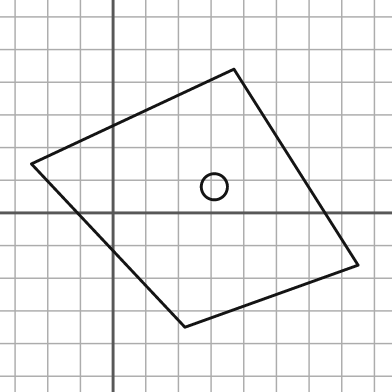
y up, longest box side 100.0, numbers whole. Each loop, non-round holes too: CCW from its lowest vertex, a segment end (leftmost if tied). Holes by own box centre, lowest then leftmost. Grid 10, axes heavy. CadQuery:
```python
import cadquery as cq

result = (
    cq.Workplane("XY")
    .moveTo(22.0, -35.0)
    .lineTo(75.0, -16.0)
    .lineTo(37.0, 44.0)
    .lineTo(-25.0, 15.0)
    .close()
    .moveTo(31.0, 8.0)
    .circle(4.0)
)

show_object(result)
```